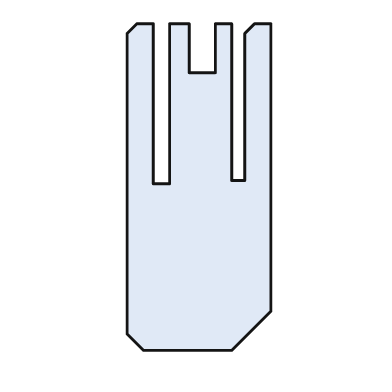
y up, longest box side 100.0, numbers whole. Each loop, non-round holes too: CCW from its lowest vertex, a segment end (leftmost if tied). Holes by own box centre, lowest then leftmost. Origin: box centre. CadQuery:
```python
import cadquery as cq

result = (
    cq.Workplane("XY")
    .moveTo(-17.0, -50.0)
    .lineTo(10.0, -50.0)
    .lineTo(22.0, -38.0)
    .lineTo(22.0, 50.0)
    .lineTo(17.0, 50.0)
    .lineTo(14.0, 47.0)
    .lineTo(14.0, 2.0)
    .lineTo(10.0, 2.0)
    .lineTo(10.0, 50.0)
    .lineTo(5.0, 50.0)
    .lineTo(5.0, 35.0)
    .lineTo(-3.0, 35.0)
    .lineTo(-3.0, 50.0)
    .lineTo(-9.0, 50.0)
    .lineTo(-9.0, 1.0)
    .lineTo(-14.0, 1.0)
    .lineTo(-14.0, 50.0)
    .lineTo(-19.0, 50.0)
    .lineTo(-22.0, 47.0)
    .lineTo(-22.0, -45.0)
    .close()
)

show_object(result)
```